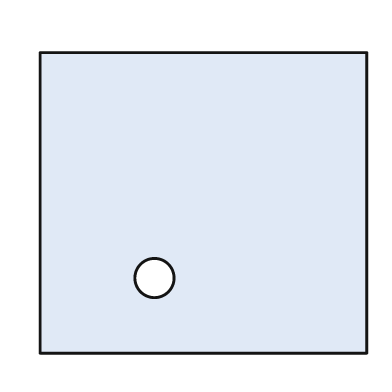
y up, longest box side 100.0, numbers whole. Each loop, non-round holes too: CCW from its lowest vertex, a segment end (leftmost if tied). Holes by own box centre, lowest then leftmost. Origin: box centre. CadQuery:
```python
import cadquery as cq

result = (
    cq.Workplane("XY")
    .moveTo(-50.0, -46.0)
    .lineTo(50.0, -46.0)
    .lineTo(50.0, 46.0)
    .lineTo(-50.0, 46.0)
    .close()
    .moveTo(-15.0, -23.0)
    .circle(6.0)
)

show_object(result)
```